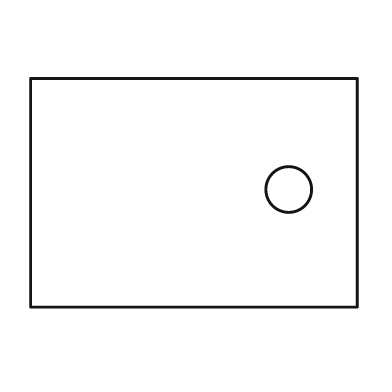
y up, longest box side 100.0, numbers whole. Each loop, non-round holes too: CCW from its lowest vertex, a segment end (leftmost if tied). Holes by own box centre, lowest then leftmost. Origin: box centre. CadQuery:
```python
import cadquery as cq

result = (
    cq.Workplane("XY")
    .moveTo(-50.0, -35.0)
    .lineTo(50.0, -35.0)
    .lineTo(50.0, 35.0)
    .lineTo(-50.0, 35.0)
    .close()
    .moveTo(29.0, 1.0)
    .circle(7.0)
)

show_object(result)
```